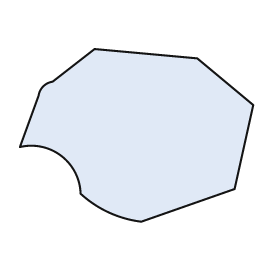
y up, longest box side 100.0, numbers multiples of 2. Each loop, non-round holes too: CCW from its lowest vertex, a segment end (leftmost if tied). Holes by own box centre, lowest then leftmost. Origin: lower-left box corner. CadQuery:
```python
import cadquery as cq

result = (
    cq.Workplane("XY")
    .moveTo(52.0, 0.0)
    .lineTo(92.0, 14.0)
    .lineTo(100.0, 50.0)
    .lineTo(76.0, 70.0)
    .lineTo(32.0, 74.0)
    .lineTo(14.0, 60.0)
    .threePointArc((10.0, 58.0), (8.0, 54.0))
    .lineTo(0.0, 32.0)
    .threePointArc((18.0, 28.0), (26.0, 12.0))
    .threePointArc((38.0, 4.0), (52.0, 0.0))
    .close()
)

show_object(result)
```